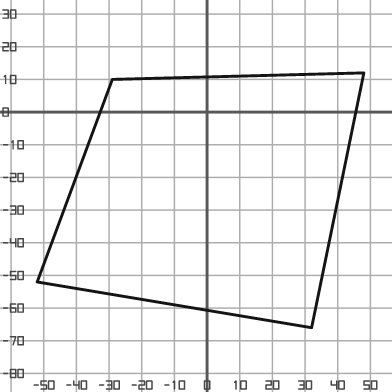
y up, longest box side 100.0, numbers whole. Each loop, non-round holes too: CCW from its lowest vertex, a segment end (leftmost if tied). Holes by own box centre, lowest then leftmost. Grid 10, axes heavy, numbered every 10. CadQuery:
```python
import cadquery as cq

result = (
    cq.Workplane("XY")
    .moveTo(32.0, -66.0)
    .lineTo(48.0, 12.0)
    .lineTo(-29.0, 10.0)
    .lineTo(-52.0, -52.0)
    .close()
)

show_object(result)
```